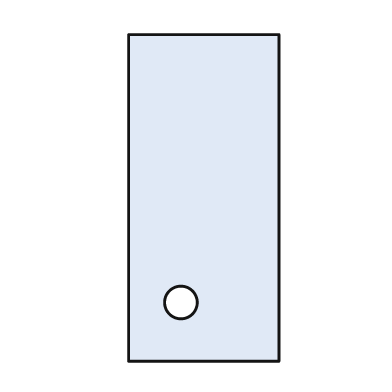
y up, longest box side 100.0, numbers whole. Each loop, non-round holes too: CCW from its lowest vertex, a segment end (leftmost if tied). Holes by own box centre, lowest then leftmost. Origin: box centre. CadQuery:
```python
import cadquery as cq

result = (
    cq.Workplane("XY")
    .moveTo(-23.0, -50.0)
    .lineTo(23.0, -50.0)
    .lineTo(23.0, 50.0)
    .lineTo(-23.0, 50.0)
    .close()
    .moveTo(-7.0, -32.0)
    .circle(5.0)
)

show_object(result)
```